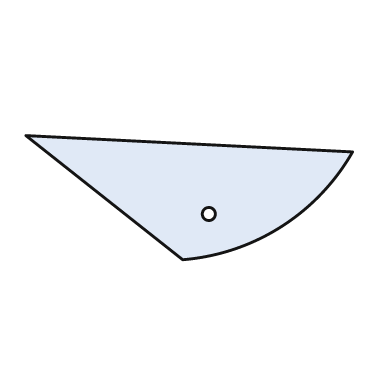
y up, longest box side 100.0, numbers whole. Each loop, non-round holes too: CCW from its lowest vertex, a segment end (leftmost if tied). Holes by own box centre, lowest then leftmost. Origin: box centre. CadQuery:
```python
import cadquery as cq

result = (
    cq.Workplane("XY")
    .moveTo(-2.0, -19.0)
    .threePointArc((28.0, -9.0), (50.0, 14.0))
    .lineTo(-50.0, 19.0)
    .close()
    .moveTo(6.0, -5.0)
    .circle(2.0)
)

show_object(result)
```